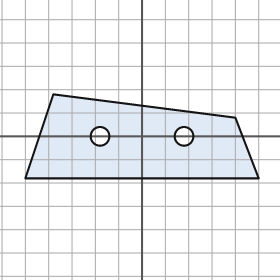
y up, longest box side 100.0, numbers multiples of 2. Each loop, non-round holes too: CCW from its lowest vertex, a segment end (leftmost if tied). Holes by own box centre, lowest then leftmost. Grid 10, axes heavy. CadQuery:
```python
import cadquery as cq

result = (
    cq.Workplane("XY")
    .moveTo(-50.0, -18.0)
    .lineTo(50.0, -18.0)
    .lineTo(40.0, 8.0)
    .lineTo(-38.0, 18.0)
    .close()
    .moveTo(-18.0, 0.0)
    .circle(4.0)
    .moveTo(18.0, 0.0)
    .circle(4.0)
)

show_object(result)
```